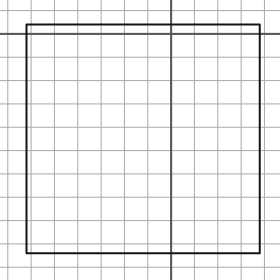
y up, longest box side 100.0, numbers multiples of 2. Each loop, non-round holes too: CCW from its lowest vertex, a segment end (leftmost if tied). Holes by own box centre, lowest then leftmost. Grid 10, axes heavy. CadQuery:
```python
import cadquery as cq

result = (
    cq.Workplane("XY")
    .moveTo(-62.0, -94.0)
    .lineTo(38.0, -94.0)
    .lineTo(38.0, 4.0)
    .lineTo(-62.0, 4.0)
    .close()
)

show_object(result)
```